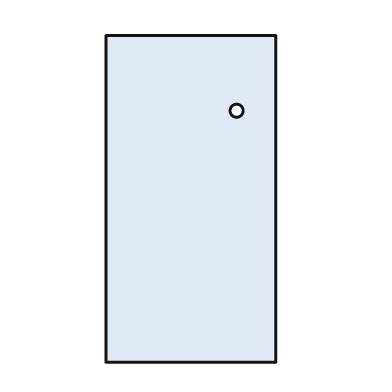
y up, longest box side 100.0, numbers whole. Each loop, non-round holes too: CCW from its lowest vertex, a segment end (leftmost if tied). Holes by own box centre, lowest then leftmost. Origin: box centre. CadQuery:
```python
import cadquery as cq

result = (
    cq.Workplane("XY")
    .moveTo(-26.0, -50.0)
    .lineTo(26.0, -50.0)
    .lineTo(26.0, 50.0)
    .lineTo(-26.0, 50.0)
    .close()
    .moveTo(14.0, 27.0)
    .circle(2.0)
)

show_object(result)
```